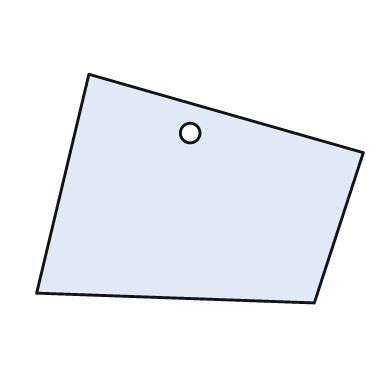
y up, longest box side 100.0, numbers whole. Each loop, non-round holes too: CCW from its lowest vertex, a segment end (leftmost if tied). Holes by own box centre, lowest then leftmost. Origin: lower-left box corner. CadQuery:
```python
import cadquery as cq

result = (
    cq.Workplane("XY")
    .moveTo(85.0, 0.0)
    .lineTo(100.0, 46.0)
    .lineTo(16.0, 70.0)
    .lineTo(0.0, 3.0)
    .close()
    .moveTo(47.0, 52.0)
    .circle(3.0)
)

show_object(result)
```